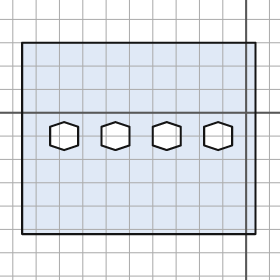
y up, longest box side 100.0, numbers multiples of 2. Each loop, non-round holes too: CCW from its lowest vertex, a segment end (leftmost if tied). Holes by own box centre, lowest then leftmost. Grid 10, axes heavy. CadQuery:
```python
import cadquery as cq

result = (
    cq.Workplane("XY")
    .moveTo(-96.0, -52.0)
    .lineTo(4.0, -52.0)
    .lineTo(4.0, 30.0)
    .lineTo(-96.0, 30.0)
    .close()
    .moveTo(-78.0, -16.0)
    .lineTo(-72.0, -14.0)
    .lineTo(-72.0, -6.0)
    .lineTo(-78.0, -4.0)
    .lineTo(-84.0, -6.0)
    .lineTo(-84.0, -14.0)
    .close()
    .moveTo(-56.0, -16.0)
    .lineTo(-50.0, -14.0)
    .lineTo(-50.0, -6.0)
    .lineTo(-56.0, -4.0)
    .lineTo(-62.0, -6.0)
    .lineTo(-62.0, -14.0)
    .close()
    .moveTo(-34.0, -16.0)
    .lineTo(-28.0, -14.0)
    .lineTo(-28.0, -6.0)
    .lineTo(-34.0, -4.0)
    .lineTo(-40.0, -6.0)
    .lineTo(-40.0, -14.0)
    .close()
    .moveTo(-12.0, -16.0)
    .lineTo(-6.0, -14.0)
    .lineTo(-6.0, -6.0)
    .lineTo(-12.0, -4.0)
    .lineTo(-18.0, -6.0)
    .lineTo(-18.0, -14.0)
    .close()
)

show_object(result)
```